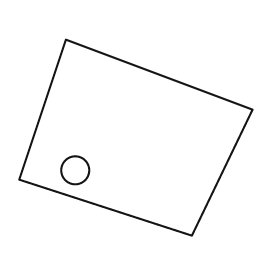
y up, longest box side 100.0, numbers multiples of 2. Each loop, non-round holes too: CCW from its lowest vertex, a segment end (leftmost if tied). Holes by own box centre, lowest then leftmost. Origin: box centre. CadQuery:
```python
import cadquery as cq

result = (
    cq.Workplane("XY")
    .moveTo(24.0, -42.0)
    .lineTo(50.0, 12.0)
    .lineTo(-30.0, 42.0)
    .lineTo(-50.0, -18.0)
    .close()
    .moveTo(-26.0, -14.0)
    .circle(6.0)
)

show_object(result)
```